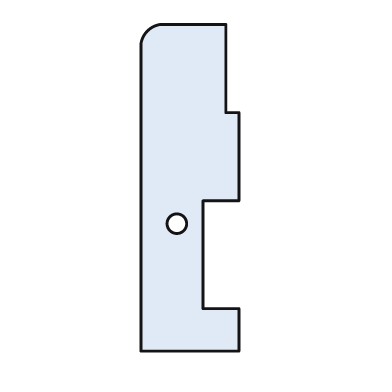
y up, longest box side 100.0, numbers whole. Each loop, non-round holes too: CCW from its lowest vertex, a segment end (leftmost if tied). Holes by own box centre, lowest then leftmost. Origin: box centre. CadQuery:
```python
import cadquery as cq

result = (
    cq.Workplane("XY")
    .moveTo(-15.0, -50.0)
    .lineTo(15.0, -50.0)
    .lineTo(15.0, -37.0)
    .lineTo(4.0, -37.0)
    .lineTo(4.0, -4.0)
    .lineTo(15.0, -4.0)
    .lineTo(15.0, 23.0)
    .lineTo(11.0, 23.0)
    .lineTo(11.0, 50.0)
    .lineTo(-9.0, 50.0)
    .threePointArc((-13.0, 48.0), (-15.0, 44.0))
    .close()
    .moveTo(-4.0, -11.0)
    .circle(3.0)
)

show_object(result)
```